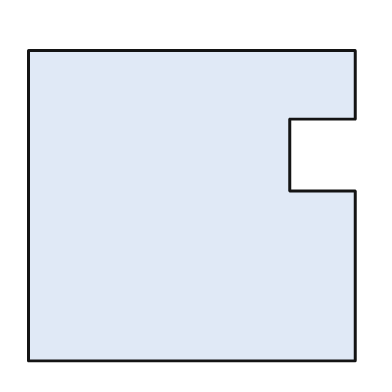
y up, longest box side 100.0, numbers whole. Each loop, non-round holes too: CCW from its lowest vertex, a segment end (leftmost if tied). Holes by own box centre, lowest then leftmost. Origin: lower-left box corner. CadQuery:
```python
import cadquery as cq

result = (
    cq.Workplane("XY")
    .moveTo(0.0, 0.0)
    .lineTo(100.0, 0.0)
    .lineTo(100.0, 52.0)
    .lineTo(80.0, 52.0)
    .lineTo(80.0, 74.0)
    .lineTo(100.0, 74.0)
    .lineTo(100.0, 95.0)
    .lineTo(0.0, 95.0)
    .close()
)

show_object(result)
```